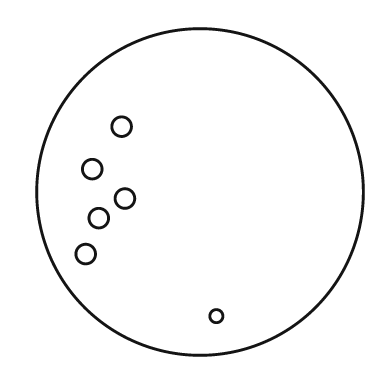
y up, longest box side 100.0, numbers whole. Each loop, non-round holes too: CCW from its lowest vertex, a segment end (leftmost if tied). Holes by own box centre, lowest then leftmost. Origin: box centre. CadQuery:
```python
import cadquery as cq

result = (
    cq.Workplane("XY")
    .moveTo(0.0, 0.0)
    .circle(50.0)
    .moveTo(5.0, -38.0)
    .circle(2.0)
    .moveTo(-35.0, -19.0)
    .circle(3.0)
    .moveTo(-31.0, -8.0)
    .circle(3.0)
    .moveTo(-23.0, -2.0)
    .circle(3.0)
    .moveTo(-33.0, 7.0)
    .circle(3.0)
    .moveTo(-24.0, 20.0)
    .circle(3.0)
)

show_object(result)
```